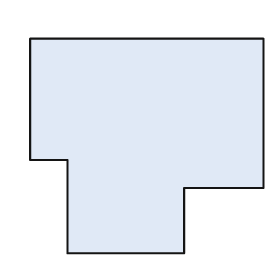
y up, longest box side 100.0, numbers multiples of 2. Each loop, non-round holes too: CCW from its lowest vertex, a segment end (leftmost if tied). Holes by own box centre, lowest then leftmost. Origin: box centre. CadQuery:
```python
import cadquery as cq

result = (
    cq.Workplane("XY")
    .moveTo(-34.0, -46.0)
    .lineTo(16.0, -46.0)
    .lineTo(16.0, -18.0)
    .lineTo(50.0, -18.0)
    .lineTo(50.0, 46.0)
    .lineTo(-50.0, 46.0)
    .lineTo(-50.0, -6.0)
    .lineTo(-34.0, -6.0)
    .close()
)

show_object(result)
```